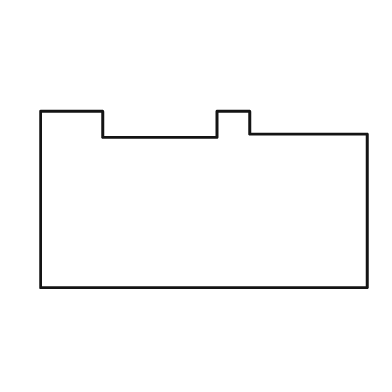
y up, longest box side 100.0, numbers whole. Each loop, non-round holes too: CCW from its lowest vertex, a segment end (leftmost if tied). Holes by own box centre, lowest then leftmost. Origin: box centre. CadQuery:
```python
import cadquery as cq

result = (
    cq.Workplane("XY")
    .moveTo(-50.0, -27.0)
    .lineTo(50.0, -27.0)
    .lineTo(50.0, 20.0)
    .lineTo(14.0, 20.0)
    .lineTo(14.0, 27.0)
    .lineTo(4.0, 27.0)
    .lineTo(4.0, 19.0)
    .lineTo(-31.0, 19.0)
    .lineTo(-31.0, 27.0)
    .lineTo(-50.0, 27.0)
    .close()
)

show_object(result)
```